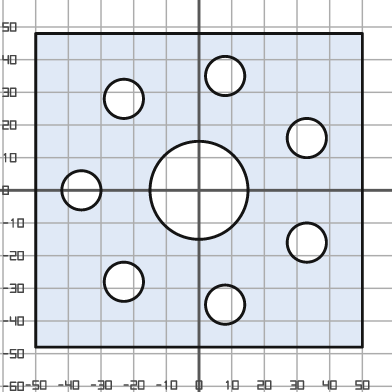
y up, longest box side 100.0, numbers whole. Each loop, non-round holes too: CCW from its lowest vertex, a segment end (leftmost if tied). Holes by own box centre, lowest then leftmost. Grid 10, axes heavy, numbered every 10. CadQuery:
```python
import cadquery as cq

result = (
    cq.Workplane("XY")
    .moveTo(-50.0, -48.0)
    .lineTo(50.0, -48.0)
    .lineTo(50.0, 48.0)
    .lineTo(-50.0, 48.0)
    .close()
    .moveTo(8.0, -35.0)
    .circle(6.0)
    .moveTo(-23.0, -28.0)
    .circle(6.0)
    .moveTo(33.0, -16.0)
    .circle(6.0)
    .moveTo(-36.0, 0.0)
    .circle(6.0)
    .moveTo(0.0, 0.0)
    .circle(15.0)
    .moveTo(33.0, 16.0)
    .circle(6.0)
    .moveTo(-23.0, 28.0)
    .circle(6.0)
    .moveTo(8.0, 35.0)
    .circle(6.0)
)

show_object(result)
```